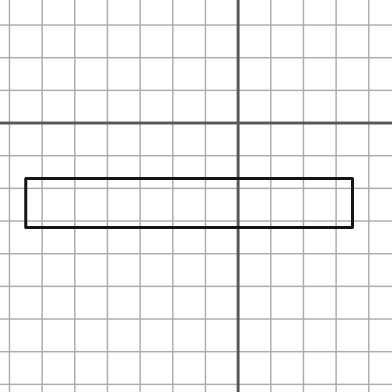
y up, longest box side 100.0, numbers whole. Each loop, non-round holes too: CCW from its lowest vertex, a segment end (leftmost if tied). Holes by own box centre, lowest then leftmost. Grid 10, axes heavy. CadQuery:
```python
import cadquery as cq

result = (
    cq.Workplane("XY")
    .moveTo(-65.0, -32.0)
    .lineTo(35.0, -32.0)
    .lineTo(35.0, -17.0)
    .lineTo(-65.0, -17.0)
    .close()
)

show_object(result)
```